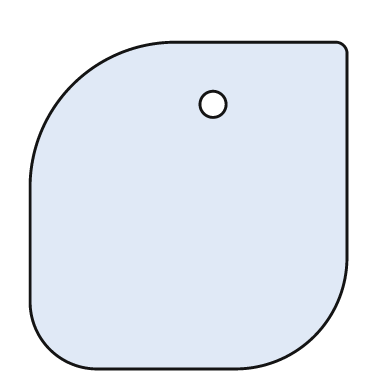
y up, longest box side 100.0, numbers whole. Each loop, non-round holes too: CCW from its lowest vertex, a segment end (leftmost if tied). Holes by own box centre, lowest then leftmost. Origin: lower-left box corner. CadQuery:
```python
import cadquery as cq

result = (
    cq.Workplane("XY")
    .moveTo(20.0, 0.0)
    .lineTo(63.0, 0.0)
    .threePointArc((87.0, 10.0), (97.0, 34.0))
    .lineTo(97.0, 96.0)
    .threePointArc((96.0, 99.0), (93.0, 100.0))
    .lineTo(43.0, 100.0)
    .threePointArc((13.0, 87.0), (0.0, 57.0))
    .lineTo(0.0, 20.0)
    .threePointArc((6.0, 6.0), (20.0, 0.0))
    .close()
    .moveTo(56.0, 81.0)
    .circle(4.0)
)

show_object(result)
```